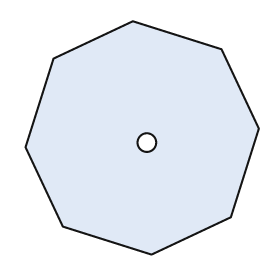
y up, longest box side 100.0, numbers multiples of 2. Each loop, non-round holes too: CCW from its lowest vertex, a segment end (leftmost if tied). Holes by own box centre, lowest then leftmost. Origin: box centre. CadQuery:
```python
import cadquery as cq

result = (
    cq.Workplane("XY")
    .moveTo(4.0, -50.0)
    .lineTo(38.0, -34.0)
    .lineTo(50.0, 4.0)
    .lineTo(34.0, 38.0)
    .lineTo(-4.0, 50.0)
    .lineTo(-38.0, 34.0)
    .lineTo(-50.0, -4.0)
    .lineTo(-34.0, -38.0)
    .close()
    .moveTo(2.0, -2.0)
    .circle(4.0)
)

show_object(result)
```